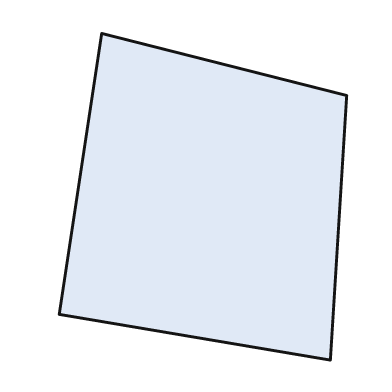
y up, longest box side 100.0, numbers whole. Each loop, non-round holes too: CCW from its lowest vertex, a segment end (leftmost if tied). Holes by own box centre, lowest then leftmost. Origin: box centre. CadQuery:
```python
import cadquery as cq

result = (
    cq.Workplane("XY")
    .moveTo(39.0, -50.0)
    .lineTo(44.0, 31.0)
    .lineTo(-31.0, 50.0)
    .lineTo(-44.0, -36.0)
    .close()
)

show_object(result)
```